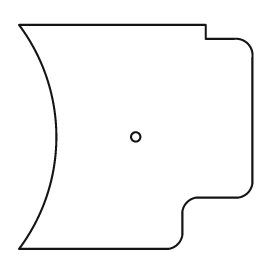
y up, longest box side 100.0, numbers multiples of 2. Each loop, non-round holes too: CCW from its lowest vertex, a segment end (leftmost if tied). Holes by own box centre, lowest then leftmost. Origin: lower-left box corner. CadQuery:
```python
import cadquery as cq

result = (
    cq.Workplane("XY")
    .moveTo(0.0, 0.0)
    .lineTo(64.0, 0.0)
    .threePointArc((68.0, 2.0), (70.0, 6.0))
    .lineTo(70.0, 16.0)
    .threePointArc((72.0, 20.0), (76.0, 22.0))
    .lineTo(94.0, 22.0)
    .threePointArc((98.0, 24.0), (100.0, 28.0))
    .lineTo(100.0, 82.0)
    .threePointArc((98.0, 88.0), (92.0, 90.0))
    .lineTo(80.0, 90.0)
    .lineTo(80.0, 96.0)
    .lineTo(0.0, 96.0)
    .threePointArc((16.0, 48.0), (0.0, 0.0))
    .close()
    .moveTo(50.0, 48.0)
    .circle(2.0)
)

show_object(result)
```